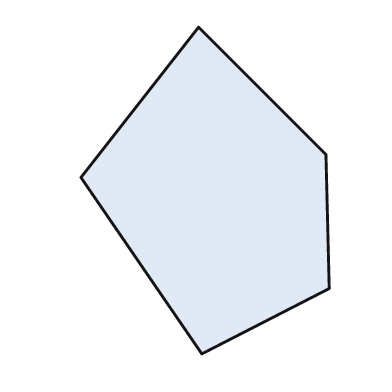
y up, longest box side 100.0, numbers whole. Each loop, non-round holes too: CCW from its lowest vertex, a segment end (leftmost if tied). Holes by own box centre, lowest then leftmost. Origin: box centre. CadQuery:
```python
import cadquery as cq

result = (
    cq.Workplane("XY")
    .moveTo(-1.0, -50.0)
    .lineTo(38.0, -30.0)
    .lineTo(37.0, 11.0)
    .lineTo(-2.0, 50.0)
    .lineTo(-38.0, 4.0)
    .close()
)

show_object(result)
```